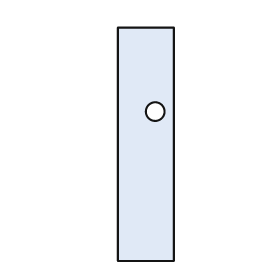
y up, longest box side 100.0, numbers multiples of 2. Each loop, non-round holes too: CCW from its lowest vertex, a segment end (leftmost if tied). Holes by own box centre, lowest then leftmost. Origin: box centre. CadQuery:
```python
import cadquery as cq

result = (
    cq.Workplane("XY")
    .moveTo(-12.0, -50.0)
    .lineTo(12.0, -50.0)
    .lineTo(12.0, 50.0)
    .lineTo(-12.0, 50.0)
    .close()
    .moveTo(4.0, 14.0)
    .circle(4.0)
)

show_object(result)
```